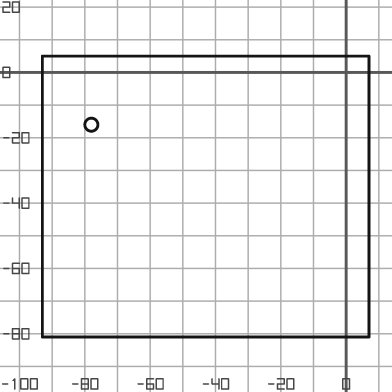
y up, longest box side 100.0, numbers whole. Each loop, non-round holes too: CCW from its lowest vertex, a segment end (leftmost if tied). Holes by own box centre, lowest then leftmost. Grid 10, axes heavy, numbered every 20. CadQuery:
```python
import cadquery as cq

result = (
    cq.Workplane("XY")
    .moveTo(-93.0, -81.0)
    .lineTo(7.0, -81.0)
    .lineTo(7.0, 5.0)
    .lineTo(-93.0, 5.0)
    .close()
    .moveTo(-78.0, -16.0)
    .circle(2.0)
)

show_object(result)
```